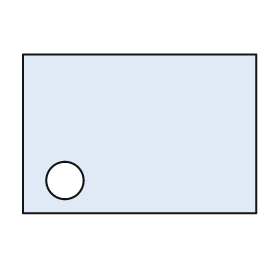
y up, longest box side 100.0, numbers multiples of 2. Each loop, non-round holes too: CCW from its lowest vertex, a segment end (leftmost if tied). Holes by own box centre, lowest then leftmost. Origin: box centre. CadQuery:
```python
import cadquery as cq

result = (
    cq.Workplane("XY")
    .moveTo(-50.0, -34.0)
    .lineTo(50.0, -34.0)
    .lineTo(50.0, 34.0)
    .lineTo(-50.0, 34.0)
    .close()
    .moveTo(-32.0, -20.0)
    .circle(8.0)
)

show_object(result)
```